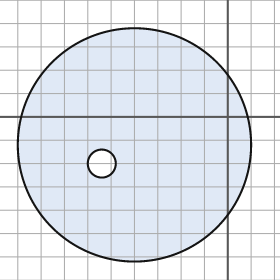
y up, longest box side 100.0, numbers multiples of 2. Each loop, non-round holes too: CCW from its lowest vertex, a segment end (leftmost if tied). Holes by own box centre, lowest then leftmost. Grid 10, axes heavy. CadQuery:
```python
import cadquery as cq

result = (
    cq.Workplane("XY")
    .moveTo(-40.0, -12.0)
    .circle(50.0)
    .moveTo(-54.0, -20.0)
    .circle(6.0)
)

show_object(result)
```